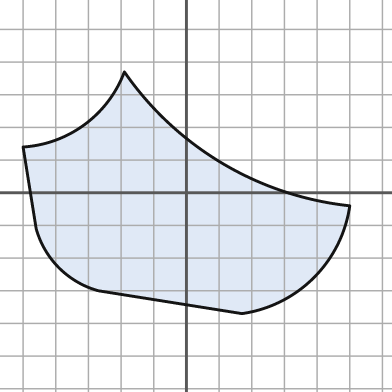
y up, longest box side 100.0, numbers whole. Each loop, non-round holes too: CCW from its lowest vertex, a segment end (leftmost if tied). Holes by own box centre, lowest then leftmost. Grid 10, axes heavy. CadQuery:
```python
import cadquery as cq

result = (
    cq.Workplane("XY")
    .moveTo(17.0, -37.0)
    .threePointArc((39.0, -26.0), (50.0, -4.0))
    .threePointArc((11.0, 9.0), (-19.0, 37.0))
    .threePointArc((-31.0, 21.0), (-50.0, 14.0))
    .lineTo(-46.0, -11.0)
    .threePointArc((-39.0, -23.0), (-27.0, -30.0))
    .close()
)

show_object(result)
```